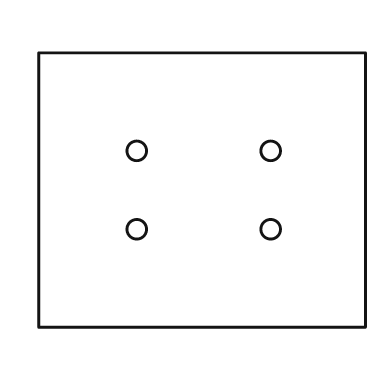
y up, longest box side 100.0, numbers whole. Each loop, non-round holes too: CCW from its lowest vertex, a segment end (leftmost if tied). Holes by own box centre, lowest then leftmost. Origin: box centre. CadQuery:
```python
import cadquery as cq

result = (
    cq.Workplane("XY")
    .moveTo(-50.0, -42.0)
    .lineTo(50.0, -42.0)
    .lineTo(50.0, 42.0)
    .lineTo(-50.0, 42.0)
    .close()
    .moveTo(-20.0, -12.0)
    .circle(3.0)
    .moveTo(21.0, -12.0)
    .circle(3.0)
    .moveTo(-20.0, 12.0)
    .circle(3.0)
    .moveTo(21.0, 12.0)
    .circle(3.0)
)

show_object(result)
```